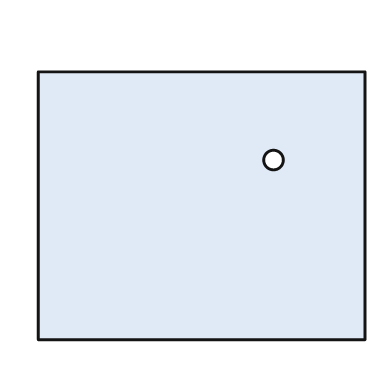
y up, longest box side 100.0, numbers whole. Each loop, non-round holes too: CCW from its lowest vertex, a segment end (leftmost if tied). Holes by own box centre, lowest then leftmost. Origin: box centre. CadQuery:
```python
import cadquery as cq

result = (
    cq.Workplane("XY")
    .moveTo(-50.0, -41.0)
    .lineTo(50.0, -41.0)
    .lineTo(50.0, 41.0)
    .lineTo(-50.0, 41.0)
    .close()
    .moveTo(22.0, 14.0)
    .circle(3.0)
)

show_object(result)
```